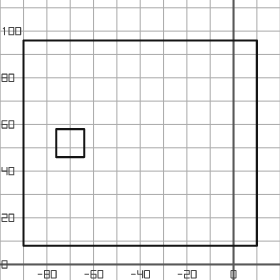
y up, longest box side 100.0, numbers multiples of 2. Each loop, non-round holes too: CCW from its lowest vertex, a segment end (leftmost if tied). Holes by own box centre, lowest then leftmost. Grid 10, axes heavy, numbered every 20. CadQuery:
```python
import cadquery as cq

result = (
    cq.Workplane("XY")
    .moveTo(-90.0, 8.0)
    .lineTo(10.0, 8.0)
    .lineTo(10.0, 96.0)
    .lineTo(-90.0, 96.0)
    .close()
    .moveTo(-76.0, 46.0)
    .lineTo(-64.0, 46.0)
    .lineTo(-64.0, 58.0)
    .lineTo(-76.0, 58.0)
    .close()
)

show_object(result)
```